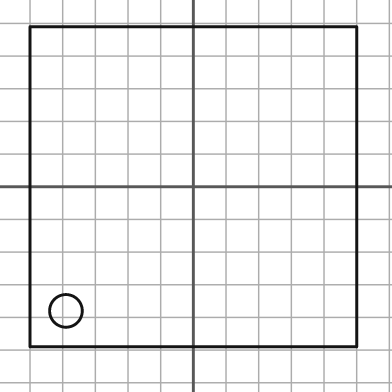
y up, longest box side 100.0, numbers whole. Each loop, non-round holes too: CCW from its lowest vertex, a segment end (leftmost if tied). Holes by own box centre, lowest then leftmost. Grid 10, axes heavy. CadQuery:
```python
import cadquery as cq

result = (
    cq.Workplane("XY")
    .moveTo(-50.0, -49.0)
    .lineTo(50.0, -49.0)
    .lineTo(50.0, 49.0)
    .lineTo(-50.0, 49.0)
    .close()
    .moveTo(-39.0, -38.0)
    .circle(5.0)
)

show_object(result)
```